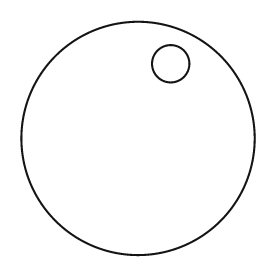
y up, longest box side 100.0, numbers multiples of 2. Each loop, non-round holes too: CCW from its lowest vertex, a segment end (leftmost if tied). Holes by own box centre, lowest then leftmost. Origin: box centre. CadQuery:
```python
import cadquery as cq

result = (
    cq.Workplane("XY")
    .moveTo(0.0, 0.0)
    .circle(50.0)
    .moveTo(14.0, 32.0)
    .circle(8.0)
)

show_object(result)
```